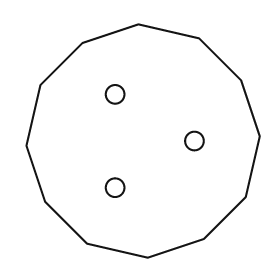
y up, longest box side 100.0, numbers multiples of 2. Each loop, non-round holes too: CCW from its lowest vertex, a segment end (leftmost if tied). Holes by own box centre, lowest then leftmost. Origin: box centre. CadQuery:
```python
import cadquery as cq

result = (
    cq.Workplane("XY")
    .moveTo(2.0, -50.0)
    .lineTo(26.0, -42.0)
    .lineTo(44.0, -24.0)
    .lineTo(50.0, 2.0)
    .lineTo(42.0, 26.0)
    .lineTo(24.0, 44.0)
    .lineTo(-2.0, 50.0)
    .lineTo(-26.0, 42.0)
    .lineTo(-44.0, 24.0)
    .lineTo(-50.0, -2.0)
    .lineTo(-42.0, -26.0)
    .lineTo(-24.0, -44.0)
    .close()
    .moveTo(-12.0, -20.0)
    .circle(4.0)
    .moveTo(22.0, 0.0)
    .circle(4.0)
    .moveTo(-12.0, 20.0)
    .circle(4.0)
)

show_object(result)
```